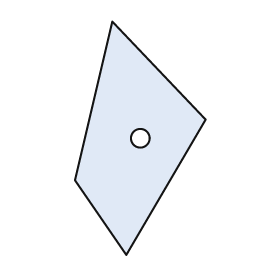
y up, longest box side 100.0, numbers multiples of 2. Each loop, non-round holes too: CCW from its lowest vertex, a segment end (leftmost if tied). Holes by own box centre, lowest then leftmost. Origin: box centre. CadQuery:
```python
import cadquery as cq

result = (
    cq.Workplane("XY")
    .moveTo(-6.0, -50.0)
    .lineTo(28.0, 8.0)
    .lineTo(-12.0, 50.0)
    .lineTo(-28.0, -18.0)
    .close()
    .moveTo(0.0, 0.0)
    .circle(4.0)
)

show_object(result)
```